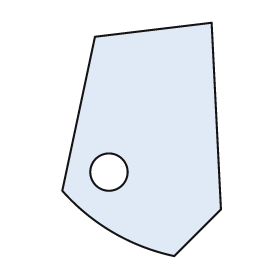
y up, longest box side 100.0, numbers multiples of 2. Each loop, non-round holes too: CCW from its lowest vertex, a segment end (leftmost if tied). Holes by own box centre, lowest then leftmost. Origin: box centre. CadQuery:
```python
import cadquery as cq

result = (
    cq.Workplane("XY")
    .moveTo(14.0, -50.0)
    .lineTo(34.0, -30.0)
    .lineTo(30.0, 50.0)
    .lineTo(-20.0, 44.0)
    .lineTo(-34.0, -22.0)
    .threePointArc((-12.0, -40.0), (14.0, -50.0))
    .close()
    .moveTo(-14.0, -14.0)
    .circle(8.0)
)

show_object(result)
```